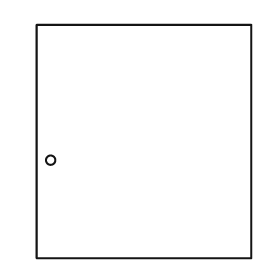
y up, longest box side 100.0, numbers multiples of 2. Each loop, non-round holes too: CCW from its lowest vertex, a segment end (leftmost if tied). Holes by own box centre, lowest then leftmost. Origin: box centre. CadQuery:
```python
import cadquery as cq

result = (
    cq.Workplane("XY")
    .moveTo(-46.0, -50.0)
    .lineTo(46.0, -50.0)
    .lineTo(46.0, 50.0)
    .lineTo(-46.0, 50.0)
    .close()
    .moveTo(-40.0, -8.0)
    .circle(2.0)
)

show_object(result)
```